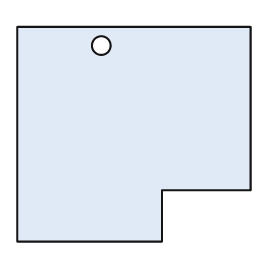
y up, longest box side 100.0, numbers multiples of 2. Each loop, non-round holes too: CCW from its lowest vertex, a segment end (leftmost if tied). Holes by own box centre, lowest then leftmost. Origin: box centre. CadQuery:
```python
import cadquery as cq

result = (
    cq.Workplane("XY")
    .moveTo(-50.0, -46.0)
    .lineTo(12.0, -46.0)
    .lineTo(12.0, -24.0)
    .lineTo(50.0, -24.0)
    .lineTo(50.0, 46.0)
    .lineTo(-50.0, 46.0)
    .close()
    .moveTo(-14.0, 38.0)
    .circle(4.0)
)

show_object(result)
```